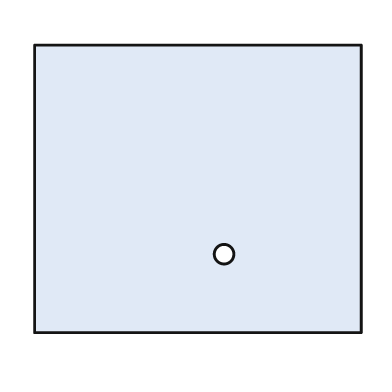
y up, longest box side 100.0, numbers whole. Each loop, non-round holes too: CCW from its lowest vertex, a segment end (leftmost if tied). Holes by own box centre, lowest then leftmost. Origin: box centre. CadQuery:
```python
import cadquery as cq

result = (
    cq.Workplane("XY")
    .moveTo(-50.0, -44.0)
    .lineTo(50.0, -44.0)
    .lineTo(50.0, 44.0)
    .lineTo(-50.0, 44.0)
    .close()
    .moveTo(8.0, -20.0)
    .circle(3.0)
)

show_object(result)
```